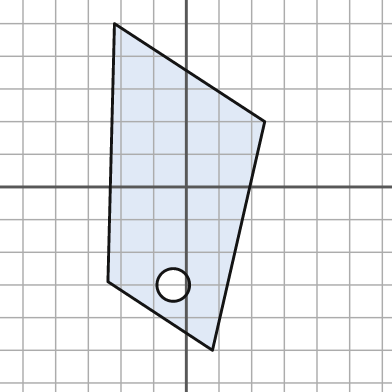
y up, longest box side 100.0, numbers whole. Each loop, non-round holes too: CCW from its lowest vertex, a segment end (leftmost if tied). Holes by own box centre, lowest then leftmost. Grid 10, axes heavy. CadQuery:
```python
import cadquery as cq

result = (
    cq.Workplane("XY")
    .moveTo(8.0, -50.0)
    .lineTo(24.0, 20.0)
    .lineTo(-22.0, 50.0)
    .lineTo(-24.0, -29.0)
    .close()
    .moveTo(-4.0, -30.0)
    .circle(5.0)
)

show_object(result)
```